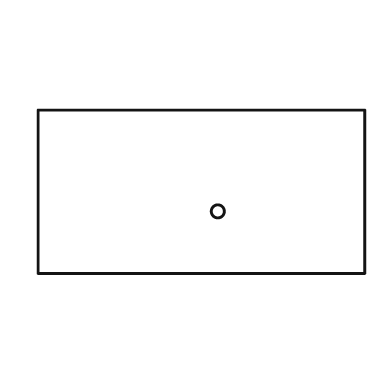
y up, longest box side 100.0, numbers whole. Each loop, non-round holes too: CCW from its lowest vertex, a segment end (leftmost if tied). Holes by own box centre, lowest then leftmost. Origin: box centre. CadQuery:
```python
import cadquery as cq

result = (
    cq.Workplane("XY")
    .moveTo(-50.0, -25.0)
    .lineTo(50.0, -25.0)
    .lineTo(50.0, 25.0)
    .lineTo(-50.0, 25.0)
    .close()
    .moveTo(5.0, -6.0)
    .circle(2.0)
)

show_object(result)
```